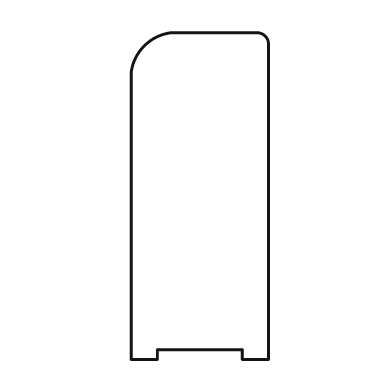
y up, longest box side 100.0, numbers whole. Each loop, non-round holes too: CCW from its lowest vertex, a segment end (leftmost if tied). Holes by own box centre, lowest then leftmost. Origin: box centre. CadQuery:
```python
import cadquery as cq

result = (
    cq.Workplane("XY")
    .moveTo(-21.0, -50.0)
    .lineTo(-13.0, -50.0)
    .lineTo(-13.0, -47.0)
    .lineTo(13.0, -47.0)
    .lineTo(13.0, -50.0)
    .lineTo(21.0, -50.0)
    .lineTo(21.0, 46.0)
    .threePointArc((20.0, 49.0), (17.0, 50.0))
    .lineTo(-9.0, 50.0)
    .threePointArc((-17.0, 46.0), (-21.0, 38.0))
    .close()
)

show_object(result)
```